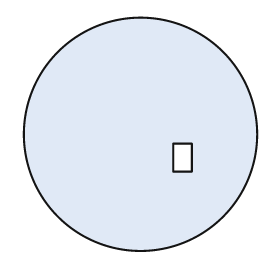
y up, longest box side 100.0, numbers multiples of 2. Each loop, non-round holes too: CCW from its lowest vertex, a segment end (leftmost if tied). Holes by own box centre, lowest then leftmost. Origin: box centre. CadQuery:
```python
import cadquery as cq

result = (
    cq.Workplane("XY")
    .moveTo(0.0, 0.0)
    .circle(50.0)
    .moveTo(14.0, -16.0)
    .lineTo(22.0, -16.0)
    .lineTo(22.0, -4.0)
    .lineTo(14.0, -4.0)
    .close()
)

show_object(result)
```